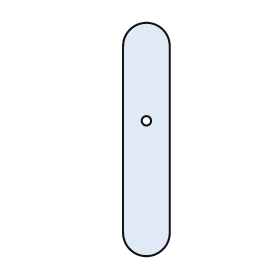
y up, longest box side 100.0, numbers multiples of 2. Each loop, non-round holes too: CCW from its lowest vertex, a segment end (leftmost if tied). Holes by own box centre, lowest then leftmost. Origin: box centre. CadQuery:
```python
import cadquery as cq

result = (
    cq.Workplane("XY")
    .moveTo(-10.0, -40.0)
    .threePointArc((0.0, -50.0), (10.0, -40.0))
    .lineTo(10.0, 40.0)
    .threePointArc((0.0, 50.0), (-10.0, 40.0))
    .close()
    .moveTo(0.0, 8.0)
    .circle(2.0)
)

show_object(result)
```